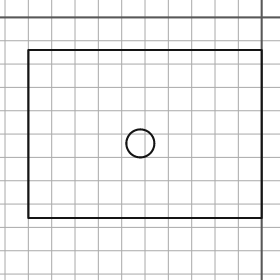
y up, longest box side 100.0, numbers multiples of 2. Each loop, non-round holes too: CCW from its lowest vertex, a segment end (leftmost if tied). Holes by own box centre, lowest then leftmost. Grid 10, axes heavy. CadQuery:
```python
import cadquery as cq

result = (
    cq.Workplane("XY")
    .moveTo(-100.0, -86.0)
    .lineTo(0.0, -86.0)
    .lineTo(0.0, -14.0)
    .lineTo(-100.0, -14.0)
    .close()
    .moveTo(-52.0, -54.0)
    .circle(6.0)
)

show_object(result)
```